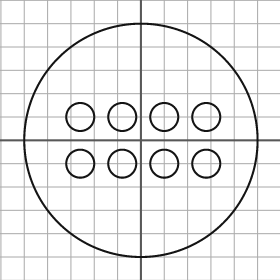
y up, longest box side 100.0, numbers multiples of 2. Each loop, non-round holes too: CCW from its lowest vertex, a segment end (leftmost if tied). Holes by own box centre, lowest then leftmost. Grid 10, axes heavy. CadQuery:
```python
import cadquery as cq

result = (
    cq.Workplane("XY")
    .moveTo(0.0, 0.0)
    .circle(50.0)
    .moveTo(-26.0, -10.0)
    .circle(6.0)
    .moveTo(-8.0, -10.0)
    .circle(6.0)
    .moveTo(10.0, -10.0)
    .circle(6.0)
    .moveTo(28.0, -10.0)
    .circle(6.0)
    .moveTo(-26.0, 10.0)
    .circle(6.0)
    .moveTo(-8.0, 10.0)
    .circle(6.0)
    .moveTo(10.0, 10.0)
    .circle(6.0)
    .moveTo(28.0, 10.0)
    .circle(6.0)
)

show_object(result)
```